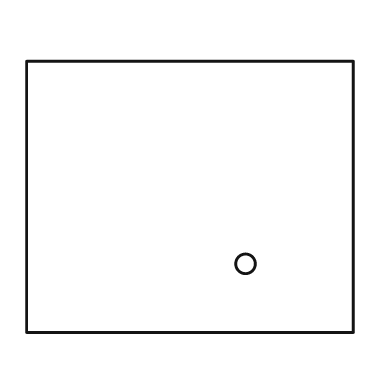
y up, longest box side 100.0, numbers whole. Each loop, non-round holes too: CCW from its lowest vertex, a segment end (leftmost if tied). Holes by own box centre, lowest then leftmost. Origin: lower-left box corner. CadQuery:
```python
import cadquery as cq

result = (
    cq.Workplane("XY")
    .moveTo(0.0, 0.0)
    .lineTo(100.0, 0.0)
    .lineTo(100.0, 83.0)
    .lineTo(0.0, 83.0)
    .close()
    .moveTo(67.0, 21.0)
    .circle(3.0)
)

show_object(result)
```